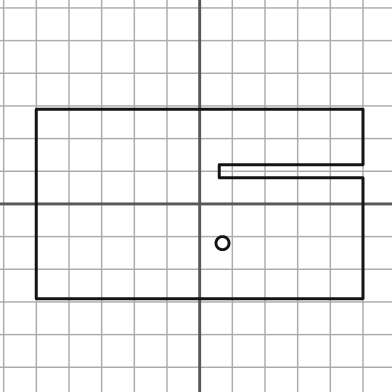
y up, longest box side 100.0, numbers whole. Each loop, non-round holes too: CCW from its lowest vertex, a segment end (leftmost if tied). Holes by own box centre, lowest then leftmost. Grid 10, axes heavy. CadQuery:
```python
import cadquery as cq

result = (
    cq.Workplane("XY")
    .moveTo(-50.0, -29.0)
    .lineTo(50.0, -29.0)
    .lineTo(50.0, 8.0)
    .lineTo(6.0, 8.0)
    .lineTo(6.0, 12.0)
    .lineTo(50.0, 12.0)
    .lineTo(50.0, 29.0)
    .lineTo(-50.0, 29.0)
    .close()
    .moveTo(7.0, -12.0)
    .circle(2.0)
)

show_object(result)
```